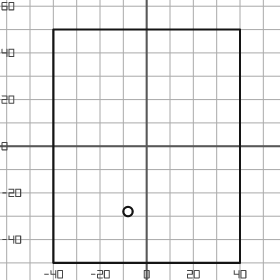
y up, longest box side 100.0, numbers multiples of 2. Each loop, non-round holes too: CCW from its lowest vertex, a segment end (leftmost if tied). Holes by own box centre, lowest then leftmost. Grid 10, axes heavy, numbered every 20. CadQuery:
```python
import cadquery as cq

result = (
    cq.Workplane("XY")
    .moveTo(-40.0, -50.0)
    .lineTo(40.0, -50.0)
    .lineTo(40.0, 50.0)
    .lineTo(-40.0, 50.0)
    .close()
    .moveTo(-8.0, -28.0)
    .circle(2.0)
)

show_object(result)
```